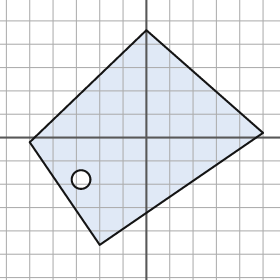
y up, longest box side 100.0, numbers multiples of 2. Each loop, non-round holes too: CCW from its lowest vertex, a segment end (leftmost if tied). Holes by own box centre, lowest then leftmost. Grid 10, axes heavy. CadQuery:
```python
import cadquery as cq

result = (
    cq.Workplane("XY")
    .moveTo(-20.0, -46.0)
    .lineTo(50.0, 2.0)
    .lineTo(0.0, 46.0)
    .lineTo(-50.0, -2.0)
    .close()
    .moveTo(-28.0, -18.0)
    .circle(4.0)
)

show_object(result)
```